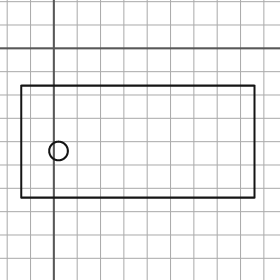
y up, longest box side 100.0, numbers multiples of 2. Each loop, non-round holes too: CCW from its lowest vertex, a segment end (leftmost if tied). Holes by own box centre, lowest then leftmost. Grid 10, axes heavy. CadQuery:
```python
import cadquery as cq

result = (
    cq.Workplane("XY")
    .moveTo(-14.0, -64.0)
    .lineTo(86.0, -64.0)
    .lineTo(86.0, -16.0)
    .lineTo(-14.0, -16.0)
    .close()
    .moveTo(2.0, -44.0)
    .circle(4.0)
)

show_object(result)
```